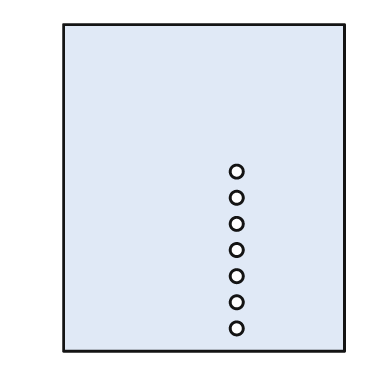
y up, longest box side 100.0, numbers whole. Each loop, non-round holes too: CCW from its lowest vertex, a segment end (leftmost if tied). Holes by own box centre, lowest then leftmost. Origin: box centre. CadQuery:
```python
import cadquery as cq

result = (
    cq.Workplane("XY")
    .moveTo(-43.0, -50.0)
    .lineTo(43.0, -50.0)
    .lineTo(43.0, 50.0)
    .lineTo(-43.0, 50.0)
    .close()
    .moveTo(10.0, -43.0)
    .circle(2.0)
    .moveTo(10.0, -35.0)
    .circle(2.0)
    .moveTo(10.0, -27.0)
    .circle(2.0)
    .moveTo(10.0, -19.0)
    .circle(2.0)
    .moveTo(10.0, -11.0)
    .circle(2.0)
    .moveTo(10.0, -3.0)
    .circle(2.0)
    .moveTo(10.0, 5.0)
    .circle(2.0)
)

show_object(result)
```